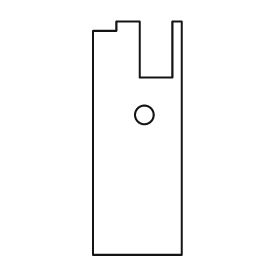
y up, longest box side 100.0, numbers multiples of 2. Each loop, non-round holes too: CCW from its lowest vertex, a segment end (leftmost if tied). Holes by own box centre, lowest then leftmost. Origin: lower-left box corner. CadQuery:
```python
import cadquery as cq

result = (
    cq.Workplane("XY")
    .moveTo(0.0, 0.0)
    .lineTo(38.0, 0.0)
    .lineTo(38.0, 100.0)
    .lineTo(34.0, 100.0)
    .lineTo(34.0, 76.0)
    .lineTo(20.0, 76.0)
    .lineTo(20.0, 100.0)
    .lineTo(10.0, 100.0)
    .lineTo(10.0, 96.0)
    .lineTo(0.0, 96.0)
    .close()
    .moveTo(22.0, 60.0)
    .circle(4.0)
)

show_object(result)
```